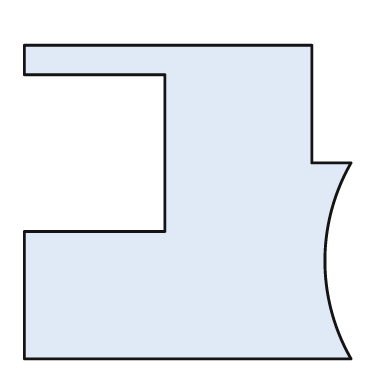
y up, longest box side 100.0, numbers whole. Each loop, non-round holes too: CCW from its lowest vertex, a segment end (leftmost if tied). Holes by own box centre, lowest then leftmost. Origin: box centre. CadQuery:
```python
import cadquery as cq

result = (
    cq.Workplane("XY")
    .moveTo(-50.0, -48.0)
    .lineTo(50.0, -48.0)
    .threePointArc((42.0, -18.0), (50.0, 12.0))
    .lineTo(38.0, 12.0)
    .lineTo(38.0, 48.0)
    .lineTo(-50.0, 48.0)
    .lineTo(-50.0, 39.0)
    .lineTo(-7.0, 39.0)
    .lineTo(-7.0, -9.0)
    .lineTo(-50.0, -9.0)
    .close()
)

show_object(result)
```